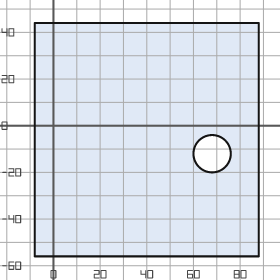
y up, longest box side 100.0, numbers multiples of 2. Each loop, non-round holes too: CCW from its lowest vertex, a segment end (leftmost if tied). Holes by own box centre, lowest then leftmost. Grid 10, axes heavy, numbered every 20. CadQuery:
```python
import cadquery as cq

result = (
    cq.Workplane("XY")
    .moveTo(-8.0, -56.0)
    .lineTo(88.0, -56.0)
    .lineTo(88.0, 44.0)
    .lineTo(-8.0, 44.0)
    .close()
    .moveTo(68.0, -12.0)
    .circle(8.0)
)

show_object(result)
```